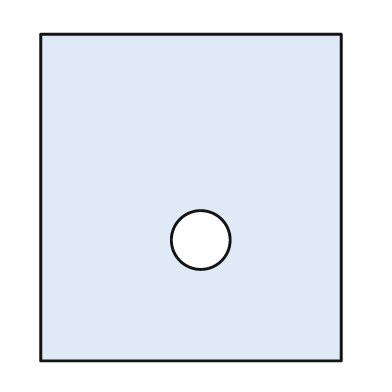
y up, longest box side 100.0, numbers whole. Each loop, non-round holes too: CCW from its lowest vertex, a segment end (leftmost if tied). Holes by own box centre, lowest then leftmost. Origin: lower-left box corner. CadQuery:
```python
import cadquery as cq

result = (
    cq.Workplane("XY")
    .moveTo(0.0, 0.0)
    .lineTo(92.0, 0.0)
    .lineTo(92.0, 100.0)
    .lineTo(0.0, 100.0)
    .close()
    .moveTo(49.0, 37.0)
    .circle(9.0)
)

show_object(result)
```